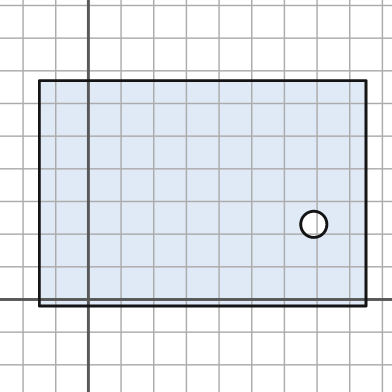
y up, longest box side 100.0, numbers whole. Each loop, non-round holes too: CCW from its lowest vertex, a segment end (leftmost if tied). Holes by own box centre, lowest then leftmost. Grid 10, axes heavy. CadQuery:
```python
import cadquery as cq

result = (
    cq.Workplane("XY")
    .moveTo(-15.0, -2.0)
    .lineTo(85.0, -2.0)
    .lineTo(85.0, 67.0)
    .lineTo(-15.0, 67.0)
    .close()
    .moveTo(69.0, 23.0)
    .circle(4.0)
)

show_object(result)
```